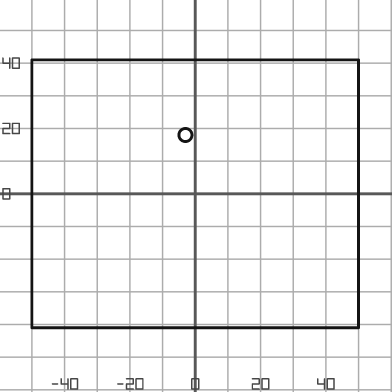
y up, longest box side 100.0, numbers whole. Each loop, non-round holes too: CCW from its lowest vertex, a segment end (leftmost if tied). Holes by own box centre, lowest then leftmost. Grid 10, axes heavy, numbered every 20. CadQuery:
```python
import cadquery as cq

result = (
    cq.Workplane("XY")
    .moveTo(-50.0, -41.0)
    .lineTo(50.0, -41.0)
    .lineTo(50.0, 41.0)
    .lineTo(-50.0, 41.0)
    .close()
    .moveTo(-3.0, 18.0)
    .circle(2.0)
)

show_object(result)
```